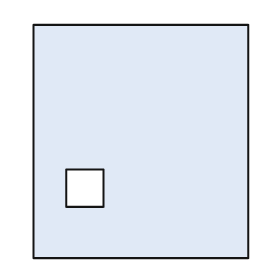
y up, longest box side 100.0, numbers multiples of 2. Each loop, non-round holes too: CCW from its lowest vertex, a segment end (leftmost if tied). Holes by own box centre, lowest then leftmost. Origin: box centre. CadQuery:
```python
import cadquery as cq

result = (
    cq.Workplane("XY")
    .moveTo(-46.0, -50.0)
    .lineTo(46.0, -50.0)
    .lineTo(46.0, 50.0)
    .lineTo(-46.0, 50.0)
    .close()
    .moveTo(-32.0, -28.0)
    .lineTo(-16.0, -28.0)
    .lineTo(-16.0, -12.0)
    .lineTo(-32.0, -12.0)
    .close()
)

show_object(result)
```